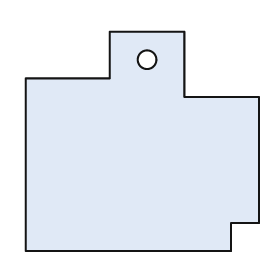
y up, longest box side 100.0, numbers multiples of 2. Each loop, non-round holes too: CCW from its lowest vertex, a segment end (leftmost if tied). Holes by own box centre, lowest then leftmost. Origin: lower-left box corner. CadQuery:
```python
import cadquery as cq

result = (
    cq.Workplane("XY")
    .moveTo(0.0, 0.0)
    .lineTo(88.0, 0.0)
    .lineTo(88.0, 12.0)
    .lineTo(100.0, 12.0)
    .lineTo(100.0, 66.0)
    .lineTo(68.0, 66.0)
    .lineTo(68.0, 94.0)
    .lineTo(36.0, 94.0)
    .lineTo(36.0, 74.0)
    .lineTo(0.0, 74.0)
    .close()
    .moveTo(52.0, 82.0)
    .circle(4.0)
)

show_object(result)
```